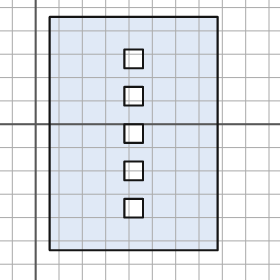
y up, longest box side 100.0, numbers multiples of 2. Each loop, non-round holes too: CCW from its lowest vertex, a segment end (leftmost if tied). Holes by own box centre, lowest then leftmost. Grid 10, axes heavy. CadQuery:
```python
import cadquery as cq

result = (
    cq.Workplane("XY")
    .moveTo(6.0, -54.0)
    .lineTo(78.0, -54.0)
    .lineTo(78.0, 46.0)
    .lineTo(6.0, 46.0)
    .close()
    .moveTo(38.0, -40.0)
    .lineTo(46.0, -40.0)
    .lineTo(46.0, -32.0)
    .lineTo(38.0, -32.0)
    .close()
    .moveTo(38.0, -24.0)
    .lineTo(46.0, -24.0)
    .lineTo(46.0, -16.0)
    .lineTo(38.0, -16.0)
    .close()
    .moveTo(38.0, -8.0)
    .lineTo(46.0, -8.0)
    .lineTo(46.0, 0.0)
    .lineTo(38.0, 0.0)
    .close()
    .moveTo(38.0, 8.0)
    .lineTo(46.0, 8.0)
    .lineTo(46.0, 16.0)
    .lineTo(38.0, 16.0)
    .close()
    .moveTo(38.0, 24.0)
    .lineTo(46.0, 24.0)
    .lineTo(46.0, 32.0)
    .lineTo(38.0, 32.0)
    .close()
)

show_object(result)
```